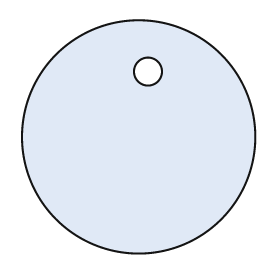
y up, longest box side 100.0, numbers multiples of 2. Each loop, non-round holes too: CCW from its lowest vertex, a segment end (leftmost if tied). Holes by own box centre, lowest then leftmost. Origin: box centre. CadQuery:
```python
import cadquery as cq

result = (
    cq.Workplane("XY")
    .moveTo(0.0, 0.0)
    .circle(50.0)
    .moveTo(4.0, 28.0)
    .circle(6.0)
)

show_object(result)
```